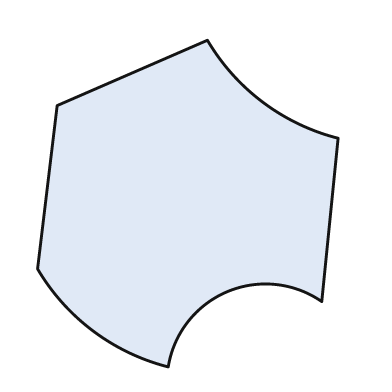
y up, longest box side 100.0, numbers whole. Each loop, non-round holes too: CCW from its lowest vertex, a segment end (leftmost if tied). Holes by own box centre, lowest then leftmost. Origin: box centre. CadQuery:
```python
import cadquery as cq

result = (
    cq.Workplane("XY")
    .moveTo(-6.0, -50.0)
    .threePointArc((12.0, -27.0), (41.0, -30.0))
    .lineTo(46.0, 20.0)
    .threePointArc((23.0, 31.0), (6.0, 50.0))
    .lineTo(-40.0, 30.0)
    .lineTo(-46.0, -20.0)
    .threePointArc((-29.0, -39.0), (-6.0, -50.0))
    .close()
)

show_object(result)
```